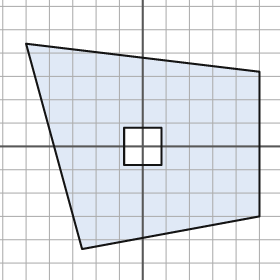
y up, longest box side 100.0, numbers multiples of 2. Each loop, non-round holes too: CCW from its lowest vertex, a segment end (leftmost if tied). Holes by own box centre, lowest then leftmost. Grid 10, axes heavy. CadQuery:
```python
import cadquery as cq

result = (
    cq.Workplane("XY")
    .moveTo(-26.0, -44.0)
    .lineTo(50.0, -30.0)
    .lineTo(50.0, 32.0)
    .lineTo(-50.0, 44.0)
    .close()
    .moveTo(-8.0, -8.0)
    .lineTo(8.0, -8.0)
    .lineTo(8.0, 8.0)
    .lineTo(-8.0, 8.0)
    .close()
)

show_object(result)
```